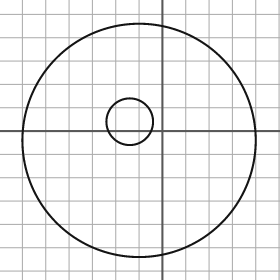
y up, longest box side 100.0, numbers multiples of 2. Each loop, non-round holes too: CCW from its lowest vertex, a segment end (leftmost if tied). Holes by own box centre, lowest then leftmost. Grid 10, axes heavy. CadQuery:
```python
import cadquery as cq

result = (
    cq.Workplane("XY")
    .moveTo(-10.0, -4.0)
    .circle(50.0)
    .moveTo(-14.0, 4.0)
    .circle(10.0)
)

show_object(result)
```